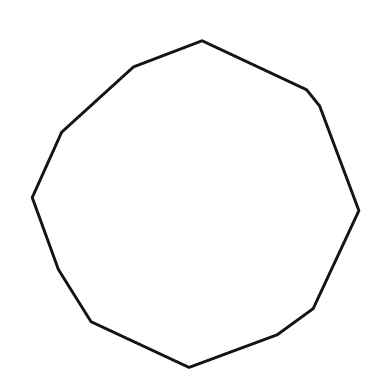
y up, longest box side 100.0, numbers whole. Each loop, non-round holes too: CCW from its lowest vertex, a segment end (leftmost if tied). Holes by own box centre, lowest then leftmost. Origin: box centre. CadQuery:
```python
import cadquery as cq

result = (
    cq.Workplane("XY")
    .moveTo(-2.0, -50.0)
    .lineTo(25.0, -40.0)
    .lineTo(36.0, -32.0)
    .lineTo(50.0, -2.0)
    .lineTo(38.0, 30.0)
    .lineTo(34.0, 35.0)
    .lineTo(2.0, 50.0)
    .lineTo(-19.0, 42.0)
    .lineTo(-41.0, 22.0)
    .lineTo(-50.0, 2.0)
    .lineTo(-42.0, -20.0)
    .lineTo(-32.0, -36.0)
    .close()
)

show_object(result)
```